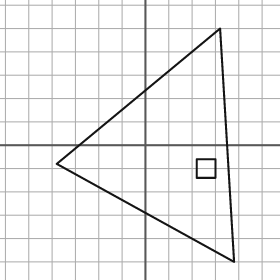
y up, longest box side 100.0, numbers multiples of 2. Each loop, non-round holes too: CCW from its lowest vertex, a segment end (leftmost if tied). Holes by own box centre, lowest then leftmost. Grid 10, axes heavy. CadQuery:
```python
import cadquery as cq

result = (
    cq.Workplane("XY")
    .moveTo(38.0, -50.0)
    .lineTo(32.0, 50.0)
    .lineTo(-38.0, -8.0)
    .close()
    .moveTo(22.0, -14.0)
    .lineTo(30.0, -14.0)
    .lineTo(30.0, -6.0)
    .lineTo(22.0, -6.0)
    .close()
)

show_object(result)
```